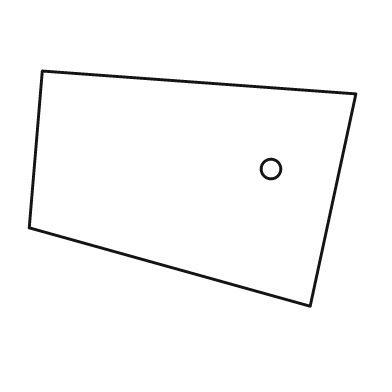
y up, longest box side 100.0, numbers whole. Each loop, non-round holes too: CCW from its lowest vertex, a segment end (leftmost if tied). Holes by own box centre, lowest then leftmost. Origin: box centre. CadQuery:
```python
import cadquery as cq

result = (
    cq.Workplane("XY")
    .moveTo(36.0, -36.0)
    .lineTo(50.0, 29.0)
    .lineTo(-46.0, 36.0)
    .lineTo(-50.0, -12.0)
    .close()
    .moveTo(24.0, 6.0)
    .circle(3.0)
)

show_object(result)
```